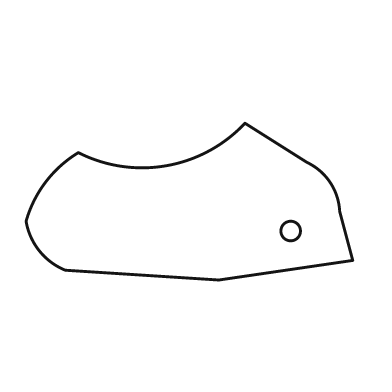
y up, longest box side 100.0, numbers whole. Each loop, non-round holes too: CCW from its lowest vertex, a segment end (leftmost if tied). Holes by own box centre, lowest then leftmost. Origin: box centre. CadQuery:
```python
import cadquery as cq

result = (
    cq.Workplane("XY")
    .moveTo(9.0, -24.0)
    .lineTo(50.0, -18.0)
    .lineTo(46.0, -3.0)
    .threePointArc((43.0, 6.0), (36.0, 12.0))
    .lineTo(17.0, 24.0)
    .threePointArc((-7.0, 11.0), (-34.0, 15.0))
    .threePointArc((-44.0, 6.0), (-50.0, -6.0))
    .threePointArc((-46.0, -15.0), (-38.0, -21.0))
    .close()
    .moveTo(31.0, -9.0)
    .circle(3.0)
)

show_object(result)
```